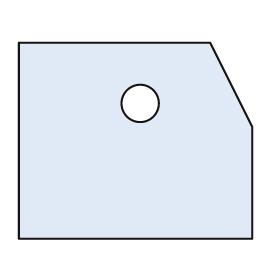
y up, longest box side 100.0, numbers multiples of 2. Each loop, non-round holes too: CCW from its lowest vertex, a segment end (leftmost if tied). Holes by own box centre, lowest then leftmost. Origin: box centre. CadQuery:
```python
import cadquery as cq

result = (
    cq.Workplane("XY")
    .moveTo(-50.0, -42.0)
    .lineTo(50.0, -42.0)
    .lineTo(50.0, 6.0)
    .lineTo(32.0, 42.0)
    .lineTo(-50.0, 42.0)
    .close()
    .moveTo(2.0, 16.0)
    .circle(8.0)
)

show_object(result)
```